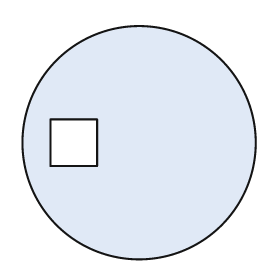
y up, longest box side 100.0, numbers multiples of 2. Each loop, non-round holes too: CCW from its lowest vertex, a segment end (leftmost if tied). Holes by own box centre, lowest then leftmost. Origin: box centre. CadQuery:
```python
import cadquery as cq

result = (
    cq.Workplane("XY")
    .moveTo(0.0, 0.0)
    .circle(50.0)
    .moveTo(-38.0, -10.0)
    .lineTo(-18.0, -10.0)
    .lineTo(-18.0, 10.0)
    .lineTo(-38.0, 10.0)
    .close()
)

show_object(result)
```